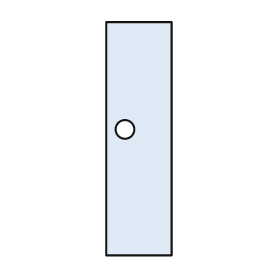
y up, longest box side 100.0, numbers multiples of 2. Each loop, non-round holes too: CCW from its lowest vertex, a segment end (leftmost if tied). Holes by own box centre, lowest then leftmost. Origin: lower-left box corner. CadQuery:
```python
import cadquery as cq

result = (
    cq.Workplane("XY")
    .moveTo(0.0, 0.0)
    .lineTo(28.0, 0.0)
    .lineTo(28.0, 100.0)
    .lineTo(0.0, 100.0)
    .close()
    .moveTo(8.0, 54.0)
    .circle(4.0)
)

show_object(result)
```